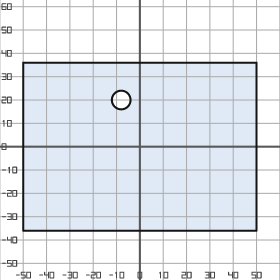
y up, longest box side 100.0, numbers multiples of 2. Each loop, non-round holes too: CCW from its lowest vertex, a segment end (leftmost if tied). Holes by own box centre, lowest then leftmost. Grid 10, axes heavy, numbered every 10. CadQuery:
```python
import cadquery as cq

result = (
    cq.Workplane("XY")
    .moveTo(-50.0, -36.0)
    .lineTo(50.0, -36.0)
    .lineTo(50.0, 36.0)
    .lineTo(-50.0, 36.0)
    .close()
    .moveTo(-8.0, 20.0)
    .circle(4.0)
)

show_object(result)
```